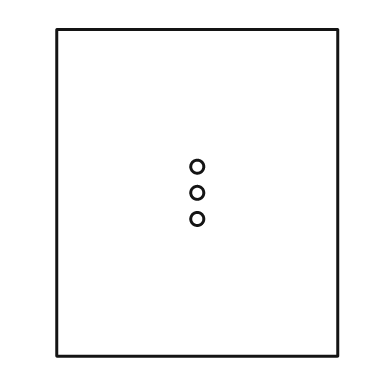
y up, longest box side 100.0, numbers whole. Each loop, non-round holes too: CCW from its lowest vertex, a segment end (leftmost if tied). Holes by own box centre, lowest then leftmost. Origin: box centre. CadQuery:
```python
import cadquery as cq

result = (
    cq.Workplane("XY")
    .moveTo(-43.0, -50.0)
    .lineTo(43.0, -50.0)
    .lineTo(43.0, 50.0)
    .lineTo(-43.0, 50.0)
    .close()
    .moveTo(0.0, -8.0)
    .circle(2.0)
    .moveTo(0.0, 0.0)
    .circle(2.0)
    .moveTo(0.0, 8.0)
    .circle(2.0)
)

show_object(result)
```